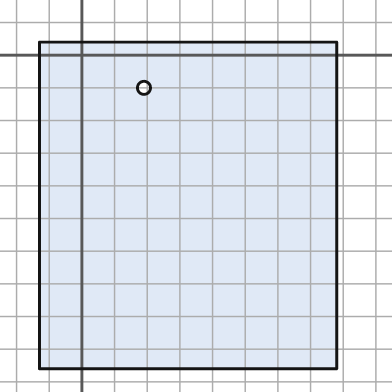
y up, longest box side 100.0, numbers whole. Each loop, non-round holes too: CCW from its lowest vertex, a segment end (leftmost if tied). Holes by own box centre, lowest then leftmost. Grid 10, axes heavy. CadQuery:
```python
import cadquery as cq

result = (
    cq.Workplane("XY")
    .moveTo(-13.0, -96.0)
    .lineTo(78.0, -96.0)
    .lineTo(78.0, 4.0)
    .lineTo(-13.0, 4.0)
    .close()
    .moveTo(19.0, -10.0)
    .circle(2.0)
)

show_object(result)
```